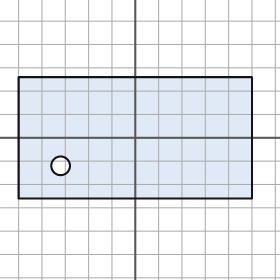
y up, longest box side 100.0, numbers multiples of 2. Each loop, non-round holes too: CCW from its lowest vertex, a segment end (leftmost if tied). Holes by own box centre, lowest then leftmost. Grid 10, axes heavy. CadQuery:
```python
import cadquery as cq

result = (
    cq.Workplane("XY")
    .moveTo(-50.0, -26.0)
    .lineTo(50.0, -26.0)
    .lineTo(50.0, 26.0)
    .lineTo(-50.0, 26.0)
    .close()
    .moveTo(-32.0, -12.0)
    .circle(4.0)
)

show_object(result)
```